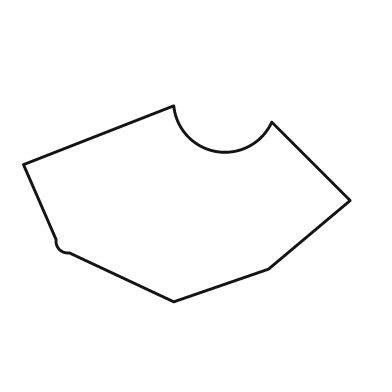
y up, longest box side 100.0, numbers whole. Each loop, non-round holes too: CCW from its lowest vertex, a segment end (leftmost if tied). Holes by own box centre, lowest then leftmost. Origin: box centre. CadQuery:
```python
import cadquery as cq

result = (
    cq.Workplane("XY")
    .moveTo(-4.0, -30.0)
    .lineTo(25.0, -20.0)
    .lineTo(50.0, 1.0)
    .lineTo(26.0, 25.0)
    .threePointArc((9.0, 16.0), (-4.0, 30.0))
    .lineTo(-50.0, 12.0)
    .lineTo(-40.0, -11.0)
    .threePointArc((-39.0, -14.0), (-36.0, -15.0))
    .close()
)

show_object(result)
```